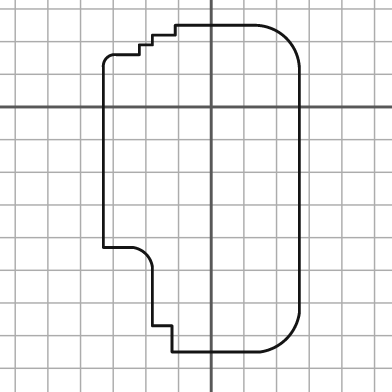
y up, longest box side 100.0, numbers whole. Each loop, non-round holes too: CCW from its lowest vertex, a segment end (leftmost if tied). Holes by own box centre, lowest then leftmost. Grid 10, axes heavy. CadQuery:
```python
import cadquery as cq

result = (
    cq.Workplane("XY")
    .moveTo(-12.0, -75.0)
    .lineTo(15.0, -75.0)
    .threePointArc((23.0, -71.0), (27.0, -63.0))
    .lineTo(27.0, 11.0)
    .threePointArc((23.0, 21.0), (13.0, 25.0))
    .lineTo(-11.0, 25.0)
    .lineTo(-11.0, 22.0)
    .lineTo(-18.0, 22.0)
    .lineTo(-18.0, 19.0)
    .lineTo(-22.0, 19.0)
    .lineTo(-22.0, 16.0)
    .lineTo(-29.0, 16.0)
    .threePointArc((-32.0, 15.0), (-33.0, 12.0))
    .lineTo(-33.0, -43.0)
    .lineTo(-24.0, -43.0)
    .threePointArc((-20.0, -45.0), (-18.0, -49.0))
    .lineTo(-18.0, -67.0)
    .lineTo(-12.0, -67.0)
    .close()
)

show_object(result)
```